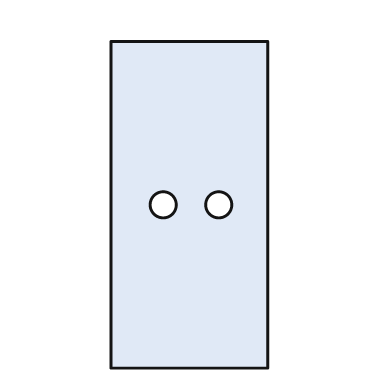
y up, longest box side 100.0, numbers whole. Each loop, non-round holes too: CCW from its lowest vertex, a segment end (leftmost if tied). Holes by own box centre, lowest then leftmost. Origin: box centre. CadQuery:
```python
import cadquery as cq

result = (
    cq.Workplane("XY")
    .moveTo(-24.0, -50.0)
    .lineTo(24.0, -50.0)
    .lineTo(24.0, 50.0)
    .lineTo(-24.0, 50.0)
    .close()
    .moveTo(-8.0, 0.0)
    .circle(4.0)
    .moveTo(9.0, 0.0)
    .circle(4.0)
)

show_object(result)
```